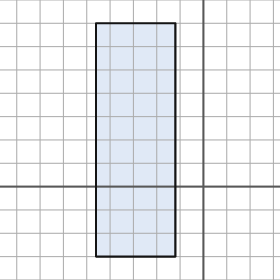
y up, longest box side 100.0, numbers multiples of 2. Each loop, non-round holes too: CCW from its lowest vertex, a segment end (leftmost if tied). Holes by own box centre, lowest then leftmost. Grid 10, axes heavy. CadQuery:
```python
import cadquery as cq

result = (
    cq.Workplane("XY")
    .moveTo(-46.0, -30.0)
    .lineTo(-12.0, -30.0)
    .lineTo(-12.0, 70.0)
    .lineTo(-46.0, 70.0)
    .close()
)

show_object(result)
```